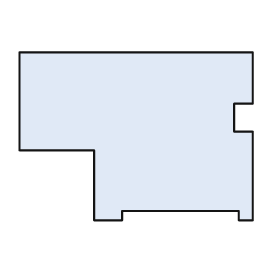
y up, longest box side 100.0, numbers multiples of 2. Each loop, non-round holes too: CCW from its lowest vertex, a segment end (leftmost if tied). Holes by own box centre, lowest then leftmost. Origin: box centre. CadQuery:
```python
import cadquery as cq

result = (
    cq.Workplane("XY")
    .moveTo(-18.0, -36.0)
    .lineTo(-6.0, -36.0)
    .lineTo(-6.0, -32.0)
    .lineTo(44.0, -32.0)
    .lineTo(44.0, -36.0)
    .lineTo(50.0, -36.0)
    .lineTo(50.0, 2.0)
    .lineTo(42.0, 2.0)
    .lineTo(42.0, 14.0)
    .lineTo(50.0, 14.0)
    .lineTo(50.0, 36.0)
    .lineTo(-50.0, 36.0)
    .lineTo(-50.0, -6.0)
    .lineTo(-18.0, -6.0)
    .close()
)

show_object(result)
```